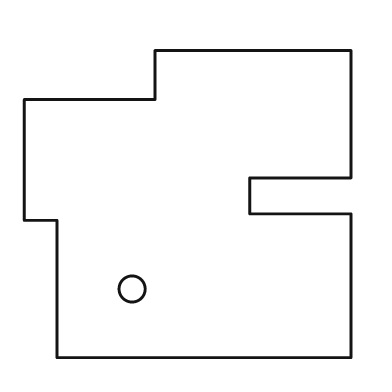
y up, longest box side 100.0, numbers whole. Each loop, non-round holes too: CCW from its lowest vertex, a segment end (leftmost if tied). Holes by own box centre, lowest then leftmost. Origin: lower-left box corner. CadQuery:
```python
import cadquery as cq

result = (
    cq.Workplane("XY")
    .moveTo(10.0, 0.0)
    .lineTo(100.0, 0.0)
    .lineTo(100.0, 44.0)
    .lineTo(69.0, 44.0)
    .lineTo(69.0, 55.0)
    .lineTo(100.0, 55.0)
    .lineTo(100.0, 94.0)
    .lineTo(40.0, 94.0)
    .lineTo(40.0, 79.0)
    .lineTo(0.0, 79.0)
    .lineTo(0.0, 42.0)
    .lineTo(10.0, 42.0)
    .close()
    .moveTo(33.0, 21.0)
    .circle(4.0)
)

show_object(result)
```